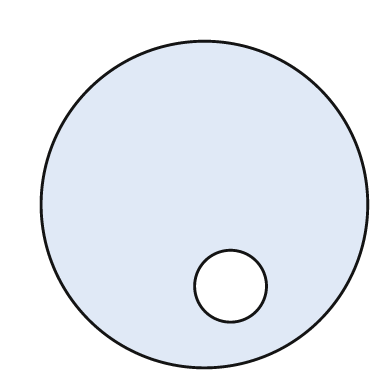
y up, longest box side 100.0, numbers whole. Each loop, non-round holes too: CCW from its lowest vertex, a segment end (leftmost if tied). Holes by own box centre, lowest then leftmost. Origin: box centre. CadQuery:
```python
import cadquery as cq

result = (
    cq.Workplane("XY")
    .moveTo(0.0, 0.0)
    .circle(50.0)
    .moveTo(8.0, -25.0)
    .circle(11.0)
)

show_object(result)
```